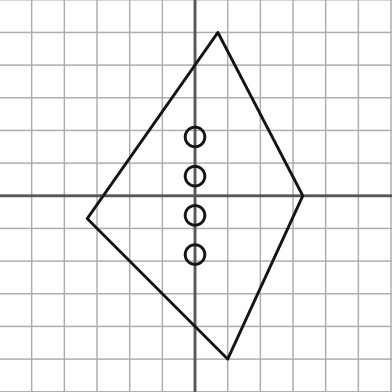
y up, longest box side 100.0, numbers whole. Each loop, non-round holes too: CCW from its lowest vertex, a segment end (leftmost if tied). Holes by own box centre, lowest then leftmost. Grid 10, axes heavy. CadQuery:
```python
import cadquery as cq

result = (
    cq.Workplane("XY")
    .moveTo(10.0, -50.0)
    .lineTo(33.0, 0.0)
    .lineTo(7.0, 50.0)
    .lineTo(-33.0, -7.0)
    .close()
    .moveTo(0.0, -18.0)
    .circle(3.0)
    .moveTo(0.0, -6.0)
    .circle(3.0)
    .moveTo(0.0, 6.0)
    .circle(3.0)
    .moveTo(0.0, 18.0)
    .circle(3.0)
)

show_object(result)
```